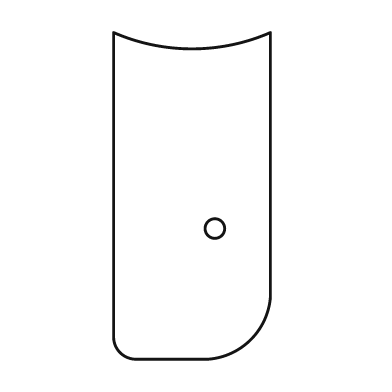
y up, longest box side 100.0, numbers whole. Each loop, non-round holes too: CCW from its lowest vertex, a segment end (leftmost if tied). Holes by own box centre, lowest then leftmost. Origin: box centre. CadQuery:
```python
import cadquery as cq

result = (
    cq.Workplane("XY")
    .moveTo(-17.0, -50.0)
    .lineTo(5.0, -50.0)
    .threePointArc((18.0, -44.0), (24.0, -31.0))
    .lineTo(24.0, 50.0)
    .threePointArc((0.0, 45.0), (-24.0, 50.0))
    .lineTo(-24.0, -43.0)
    .threePointArc((-22.0, -48.0), (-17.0, -50.0))
    .close()
    .moveTo(7.0, -10.0)
    .circle(3.0)
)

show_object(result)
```